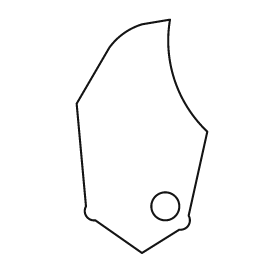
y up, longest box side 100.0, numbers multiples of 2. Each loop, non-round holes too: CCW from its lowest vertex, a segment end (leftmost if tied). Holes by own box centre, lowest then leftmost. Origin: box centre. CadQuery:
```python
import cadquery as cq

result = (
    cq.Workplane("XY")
    .moveTo(0.0, -50.0)
    .lineTo(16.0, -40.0)
    .threePointArc((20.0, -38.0), (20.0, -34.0))
    .lineTo(28.0, 2.0)
    .threePointArc((14.0, 24.0), (12.0, 50.0))
    .lineTo(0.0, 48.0)
    .threePointArc((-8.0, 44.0), (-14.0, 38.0))
    .lineTo(-28.0, 14.0)
    .lineTo(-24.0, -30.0)
    .threePointArc((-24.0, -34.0), (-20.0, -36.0))
    .close()
    .moveTo(10.0, -30.0)
    .circle(6.0)
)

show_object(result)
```